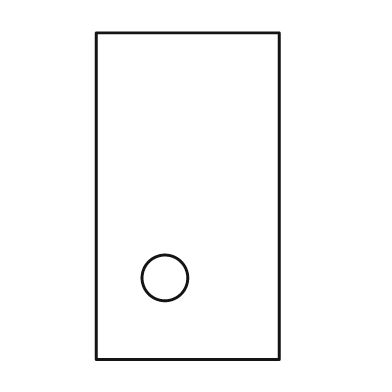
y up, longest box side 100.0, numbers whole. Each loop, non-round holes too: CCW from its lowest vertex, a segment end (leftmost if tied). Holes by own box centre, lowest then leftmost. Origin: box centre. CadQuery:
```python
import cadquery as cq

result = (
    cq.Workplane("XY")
    .moveTo(-28.0, -50.0)
    .lineTo(28.0, -50.0)
    .lineTo(28.0, 50.0)
    .lineTo(-28.0, 50.0)
    .close()
    .moveTo(-7.0, -25.0)
    .circle(7.0)
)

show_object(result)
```